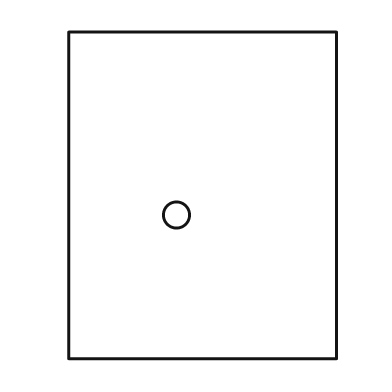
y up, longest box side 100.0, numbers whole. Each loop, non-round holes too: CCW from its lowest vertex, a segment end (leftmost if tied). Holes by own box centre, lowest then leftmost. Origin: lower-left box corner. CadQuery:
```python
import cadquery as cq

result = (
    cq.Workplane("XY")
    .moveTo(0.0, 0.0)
    .lineTo(82.0, 0.0)
    .lineTo(82.0, 100.0)
    .lineTo(0.0, 100.0)
    .close()
    .moveTo(33.0, 44.0)
    .circle(4.0)
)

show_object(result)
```